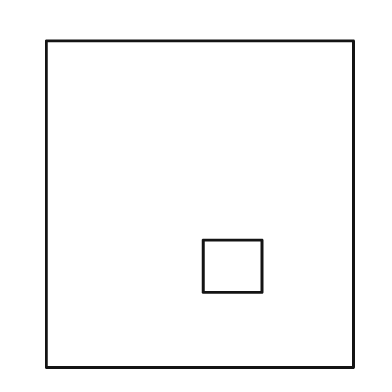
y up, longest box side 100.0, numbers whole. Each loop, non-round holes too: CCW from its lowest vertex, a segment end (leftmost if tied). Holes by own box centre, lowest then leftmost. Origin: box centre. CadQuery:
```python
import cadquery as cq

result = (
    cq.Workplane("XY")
    .moveTo(-47.0, -50.0)
    .lineTo(47.0, -50.0)
    .lineTo(47.0, 50.0)
    .lineTo(-47.0, 50.0)
    .close()
    .moveTo(1.0, -27.0)
    .lineTo(19.0, -27.0)
    .lineTo(19.0, -11.0)
    .lineTo(1.0, -11.0)
    .close()
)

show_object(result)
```